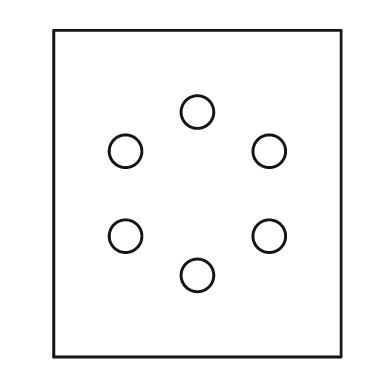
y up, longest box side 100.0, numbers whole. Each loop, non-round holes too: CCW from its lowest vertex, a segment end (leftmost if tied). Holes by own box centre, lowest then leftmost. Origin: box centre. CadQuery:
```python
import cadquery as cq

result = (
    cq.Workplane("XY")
    .moveTo(-44.0, -50.0)
    .lineTo(44.0, -50.0)
    .lineTo(44.0, 50.0)
    .lineTo(-44.0, 50.0)
    .close()
    .moveTo(0.0, -25.0)
    .circle(5.0)
    .moveTo(-22.0, -13.0)
    .circle(5.0)
    .moveTo(22.0, -13.0)
    .circle(5.0)
    .moveTo(-22.0, 13.0)
    .circle(5.0)
    .moveTo(22.0, 13.0)
    .circle(5.0)
    .moveTo(0.0, 25.0)
    .circle(5.0)
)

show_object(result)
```